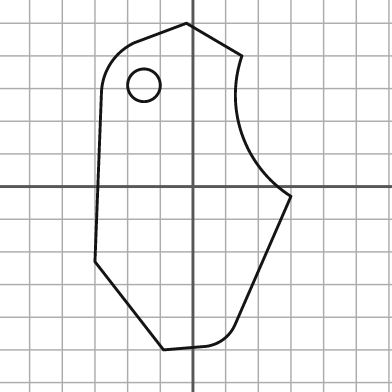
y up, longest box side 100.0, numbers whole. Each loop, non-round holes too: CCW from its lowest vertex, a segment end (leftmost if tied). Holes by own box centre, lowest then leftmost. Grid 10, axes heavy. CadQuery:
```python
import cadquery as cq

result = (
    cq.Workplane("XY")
    .moveTo(-9.0, -50.0)
    .lineTo(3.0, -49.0)
    .threePointArc((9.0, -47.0), (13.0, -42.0))
    .lineTo(30.0, -3.0)
    .threePointArc((15.0, 16.0), (15.0, 40.0))
    .lineTo(-2.0, 50.0)
    .lineTo(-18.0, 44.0)
    .threePointArc((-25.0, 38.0), (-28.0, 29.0))
    .lineTo(-30.0, -23.0)
    .close()
    .moveTo(-15.0, 31.0)
    .circle(5.0)
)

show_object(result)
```